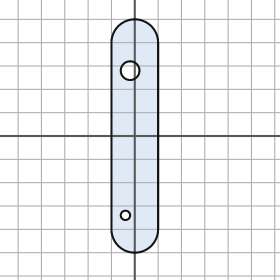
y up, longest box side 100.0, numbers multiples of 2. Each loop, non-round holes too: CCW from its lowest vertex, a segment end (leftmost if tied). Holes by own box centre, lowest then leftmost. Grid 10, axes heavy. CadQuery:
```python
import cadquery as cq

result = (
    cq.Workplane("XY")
    .moveTo(-10.0, -40.0)
    .threePointArc((0.0, -50.0), (10.0, -40.0))
    .lineTo(10.0, 40.0)
    .threePointArc((0.0, 50.0), (-10.0, 40.0))
    .close()
    .moveTo(-4.0, -34.0)
    .circle(2.0)
    .moveTo(-2.0, 28.0)
    .circle(4.0)
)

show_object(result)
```